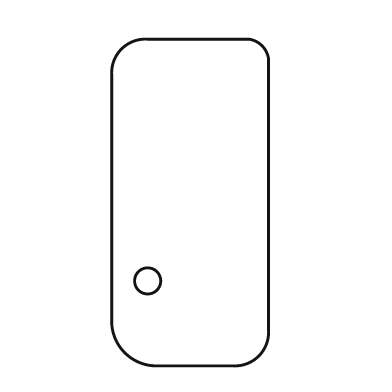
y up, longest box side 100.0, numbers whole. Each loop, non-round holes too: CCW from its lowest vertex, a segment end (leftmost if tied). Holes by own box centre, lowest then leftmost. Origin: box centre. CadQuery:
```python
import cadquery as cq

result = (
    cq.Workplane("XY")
    .moveTo(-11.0, -50.0)
    .lineTo(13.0, -50.0)
    .threePointArc((21.0, -47.0), (24.0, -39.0))
    .lineTo(24.0, 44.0)
    .threePointArc((22.0, 48.0), (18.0, 50.0))
    .lineTo(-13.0, 50.0)
    .threePointArc((-21.0, 47.0), (-24.0, 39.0))
    .lineTo(-24.0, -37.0)
    .threePointArc((-20.0, -46.0), (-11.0, -50.0))
    .close()
    .moveTo(-13.0, -24.0)
    .circle(4.0)
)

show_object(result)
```